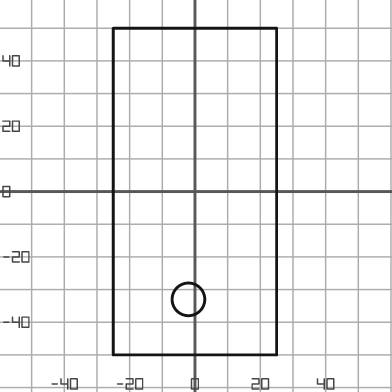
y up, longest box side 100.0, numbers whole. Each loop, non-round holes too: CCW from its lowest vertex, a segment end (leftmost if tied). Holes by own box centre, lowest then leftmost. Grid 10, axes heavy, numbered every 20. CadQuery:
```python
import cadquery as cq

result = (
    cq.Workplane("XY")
    .moveTo(-25.0, -50.0)
    .lineTo(25.0, -50.0)
    .lineTo(25.0, 50.0)
    .lineTo(-25.0, 50.0)
    .close()
    .moveTo(-2.0, -33.0)
    .circle(5.0)
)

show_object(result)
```